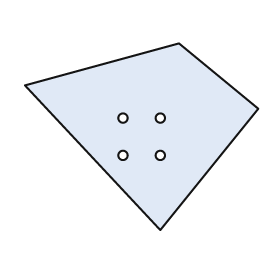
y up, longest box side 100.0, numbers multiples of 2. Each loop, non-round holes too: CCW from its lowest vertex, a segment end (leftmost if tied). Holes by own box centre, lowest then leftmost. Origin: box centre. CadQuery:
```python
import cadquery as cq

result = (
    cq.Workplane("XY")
    .moveTo(8.0, -40.0)
    .lineTo(50.0, 12.0)
    .lineTo(16.0, 40.0)
    .lineTo(-50.0, 22.0)
    .close()
    .moveTo(-8.0, -8.0)
    .circle(2.0)
    .moveTo(8.0, -8.0)
    .circle(2.0)
    .moveTo(-8.0, 8.0)
    .circle(2.0)
    .moveTo(8.0, 8.0)
    .circle(2.0)
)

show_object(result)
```